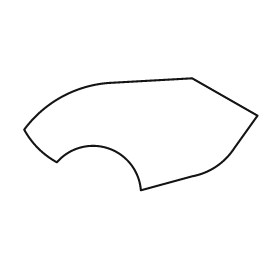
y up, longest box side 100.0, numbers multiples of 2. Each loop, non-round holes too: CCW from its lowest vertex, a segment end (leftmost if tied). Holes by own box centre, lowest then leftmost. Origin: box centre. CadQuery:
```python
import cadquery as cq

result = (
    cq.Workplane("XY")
    .moveTo(0.0, -24.0)
    .lineTo(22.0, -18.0)
    .threePointArc((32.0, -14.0), (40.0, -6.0))
    .lineTo(50.0, 8.0)
    .lineTo(22.0, 24.0)
    .lineTo(-14.0, 22.0)
    .threePointArc((-34.0, 16.0), (-50.0, 2.0))
    .threePointArc((-44.0, -6.0), (-36.0, -12.0))
    .threePointArc((-14.0, -6.0), (0.0, -24.0))
    .close()
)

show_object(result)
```